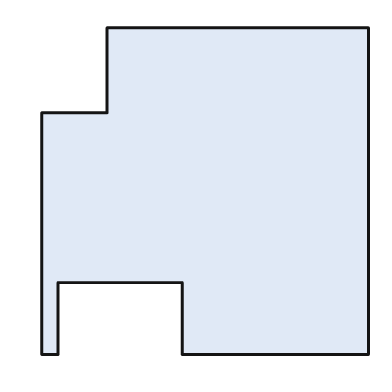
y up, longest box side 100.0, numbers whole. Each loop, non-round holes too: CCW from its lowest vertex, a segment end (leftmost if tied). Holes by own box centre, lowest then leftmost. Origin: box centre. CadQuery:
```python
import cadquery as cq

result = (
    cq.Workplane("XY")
    .moveTo(-50.0, -50.0)
    .lineTo(-45.0, -50.0)
    .lineTo(-45.0, -28.0)
    .lineTo(-7.0, -28.0)
    .lineTo(-7.0, -50.0)
    .lineTo(50.0, -50.0)
    .lineTo(50.0, 50.0)
    .lineTo(-30.0, 50.0)
    .lineTo(-30.0, 24.0)
    .lineTo(-50.0, 24.0)
    .close()
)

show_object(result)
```